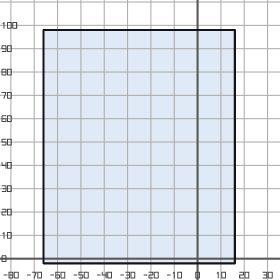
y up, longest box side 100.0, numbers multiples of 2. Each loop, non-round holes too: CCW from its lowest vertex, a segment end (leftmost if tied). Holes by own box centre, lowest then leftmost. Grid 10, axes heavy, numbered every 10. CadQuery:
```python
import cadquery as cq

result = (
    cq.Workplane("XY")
    .moveTo(-66.0, -2.0)
    .lineTo(16.0, -2.0)
    .lineTo(16.0, 98.0)
    .lineTo(-66.0, 98.0)
    .close()
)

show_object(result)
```